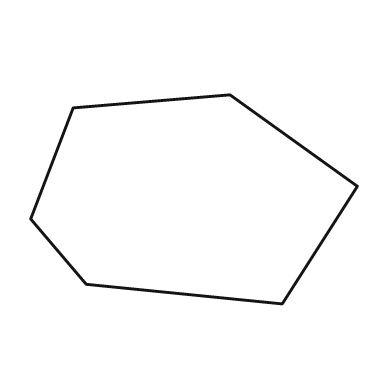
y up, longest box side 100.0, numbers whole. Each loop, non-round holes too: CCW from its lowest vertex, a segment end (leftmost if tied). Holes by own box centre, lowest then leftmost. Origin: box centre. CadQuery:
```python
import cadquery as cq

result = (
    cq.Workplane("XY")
    .moveTo(27.0, -32.0)
    .lineTo(50.0, 4.0)
    .lineTo(11.0, 32.0)
    .lineTo(-37.0, 28.0)
    .lineTo(-50.0, -6.0)
    .lineTo(-33.0, -26.0)
    .close()
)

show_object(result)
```